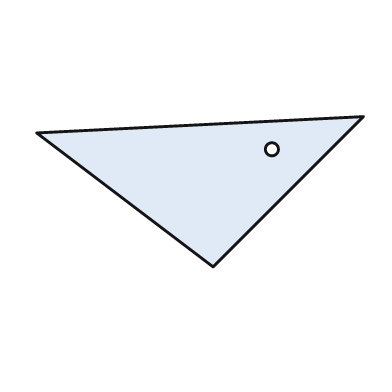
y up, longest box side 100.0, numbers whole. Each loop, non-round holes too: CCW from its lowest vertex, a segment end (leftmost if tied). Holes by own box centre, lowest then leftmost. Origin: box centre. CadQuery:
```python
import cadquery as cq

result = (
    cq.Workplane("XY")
    .moveTo(4.0, -23.0)
    .lineTo(50.0, 23.0)
    .lineTo(-50.0, 18.0)
    .close()
    .moveTo(22.0, 13.0)
    .circle(2.0)
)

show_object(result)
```